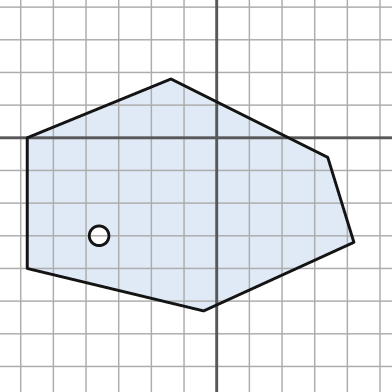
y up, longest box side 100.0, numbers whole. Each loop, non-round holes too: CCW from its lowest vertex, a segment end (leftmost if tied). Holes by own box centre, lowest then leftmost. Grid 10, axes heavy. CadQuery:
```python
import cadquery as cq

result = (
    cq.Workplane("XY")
    .moveTo(-4.0, -53.0)
    .lineTo(42.0, -32.0)
    .lineTo(34.0, -6.0)
    .lineTo(-14.0, 18.0)
    .lineTo(-58.0, 0.0)
    .lineTo(-58.0, -40.0)
    .close()
    .moveTo(-36.0, -30.0)
    .circle(3.0)
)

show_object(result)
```